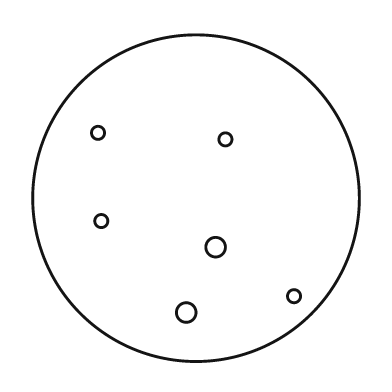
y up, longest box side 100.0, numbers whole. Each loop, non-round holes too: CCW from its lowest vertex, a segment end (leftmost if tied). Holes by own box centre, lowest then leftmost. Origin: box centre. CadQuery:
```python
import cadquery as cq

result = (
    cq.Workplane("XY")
    .moveTo(0.0, 0.0)
    .circle(50.0)
    .moveTo(-3.0, -35.0)
    .circle(3.0)
    .moveTo(30.0, -30.0)
    .circle(2.0)
    .moveTo(6.0, -15.0)
    .circle(3.0)
    .moveTo(-29.0, -7.0)
    .circle(2.0)
    .moveTo(9.0, 18.0)
    .circle(2.0)
    .moveTo(-30.0, 20.0)
    .circle(2.0)
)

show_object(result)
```